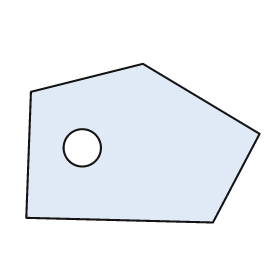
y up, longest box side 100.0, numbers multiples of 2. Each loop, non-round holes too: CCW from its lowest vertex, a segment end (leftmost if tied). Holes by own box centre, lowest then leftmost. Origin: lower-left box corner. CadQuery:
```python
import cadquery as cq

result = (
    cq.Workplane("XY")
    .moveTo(80.0, 0.0)
    .lineTo(100.0, 38.0)
    .lineTo(50.0, 68.0)
    .lineTo(2.0, 56.0)
    .lineTo(0.0, 2.0)
    .close()
    .moveTo(24.0, 32.0)
    .circle(8.0)
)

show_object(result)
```